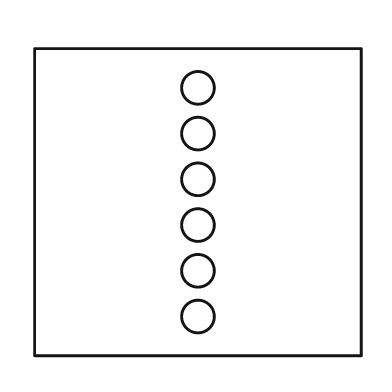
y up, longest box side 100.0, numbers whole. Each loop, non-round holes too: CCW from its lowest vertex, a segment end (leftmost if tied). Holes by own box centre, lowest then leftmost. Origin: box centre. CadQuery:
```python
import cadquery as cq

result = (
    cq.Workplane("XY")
    .moveTo(-50.0, -47.0)
    .lineTo(50.0, -47.0)
    .lineTo(50.0, 47.0)
    .lineTo(-50.0, 47.0)
    .close()
    .moveTo(0.0, -35.0)
    .circle(5.0)
    .moveTo(0.0, -21.0)
    .circle(5.0)
    .moveTo(0.0, -7.0)
    .circle(5.0)
    .moveTo(0.0, 7.0)
    .circle(5.0)
    .moveTo(0.0, 21.0)
    .circle(5.0)
    .moveTo(0.0, 35.0)
    .circle(5.0)
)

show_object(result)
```